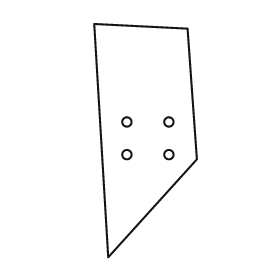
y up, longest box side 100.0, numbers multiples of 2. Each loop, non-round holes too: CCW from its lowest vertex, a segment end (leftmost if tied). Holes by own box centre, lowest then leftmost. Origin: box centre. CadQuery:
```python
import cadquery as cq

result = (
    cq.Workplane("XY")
    .moveTo(-16.0, -50.0)
    .lineTo(22.0, -8.0)
    .lineTo(18.0, 48.0)
    .lineTo(-22.0, 50.0)
    .close()
    .moveTo(-8.0, -6.0)
    .circle(2.0)
    .moveTo(10.0, -6.0)
    .circle(2.0)
    .moveTo(-8.0, 8.0)
    .circle(2.0)
    .moveTo(10.0, 8.0)
    .circle(2.0)
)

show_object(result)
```